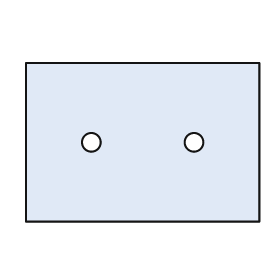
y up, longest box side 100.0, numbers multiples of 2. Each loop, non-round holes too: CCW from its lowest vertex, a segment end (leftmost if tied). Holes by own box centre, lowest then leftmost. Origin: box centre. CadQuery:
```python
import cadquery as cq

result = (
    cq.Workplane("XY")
    .moveTo(-50.0, -34.0)
    .lineTo(50.0, -34.0)
    .lineTo(50.0, 34.0)
    .lineTo(-50.0, 34.0)
    .close()
    .moveTo(-22.0, 0.0)
    .circle(4.0)
    .moveTo(22.0, 0.0)
    .circle(4.0)
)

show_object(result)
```